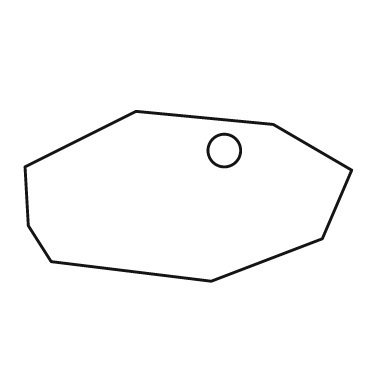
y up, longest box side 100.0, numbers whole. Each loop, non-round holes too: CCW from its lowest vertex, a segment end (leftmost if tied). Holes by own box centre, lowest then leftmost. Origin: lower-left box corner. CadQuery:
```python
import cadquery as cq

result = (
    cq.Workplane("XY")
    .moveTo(57.0, 0.0)
    .lineTo(91.0, 13.0)
    .lineTo(100.0, 34.0)
    .lineTo(76.0, 48.0)
    .lineTo(34.0, 52.0)
    .lineTo(0.0, 35.0)
    .lineTo(1.0, 17.0)
    .lineTo(8.0, 6.0)
    .close()
    .moveTo(61.0, 40.0)
    .circle(5.0)
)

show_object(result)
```